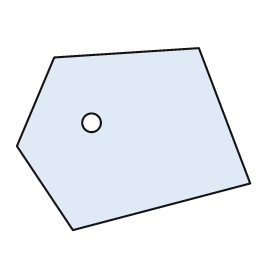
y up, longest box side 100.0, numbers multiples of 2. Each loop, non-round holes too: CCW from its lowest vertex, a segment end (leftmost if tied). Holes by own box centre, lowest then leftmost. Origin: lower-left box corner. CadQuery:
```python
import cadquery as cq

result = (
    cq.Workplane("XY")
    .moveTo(24.0, 0.0)
    .lineTo(100.0, 20.0)
    .lineTo(78.0, 78.0)
    .lineTo(16.0, 74.0)
    .lineTo(0.0, 36.0)
    .close()
    .moveTo(32.0, 46.0)
    .circle(4.0)
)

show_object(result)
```